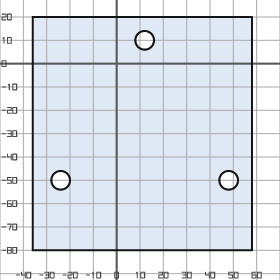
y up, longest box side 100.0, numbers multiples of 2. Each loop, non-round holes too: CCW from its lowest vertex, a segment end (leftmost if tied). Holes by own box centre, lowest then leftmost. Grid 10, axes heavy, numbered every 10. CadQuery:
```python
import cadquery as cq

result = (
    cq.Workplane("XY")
    .moveTo(-36.0, -80.0)
    .lineTo(58.0, -80.0)
    .lineTo(58.0, 20.0)
    .lineTo(-36.0, 20.0)
    .close()
    .moveTo(-24.0, -50.0)
    .circle(4.0)
    .moveTo(48.0, -50.0)
    .circle(4.0)
    .moveTo(12.0, 10.0)
    .circle(4.0)
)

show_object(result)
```